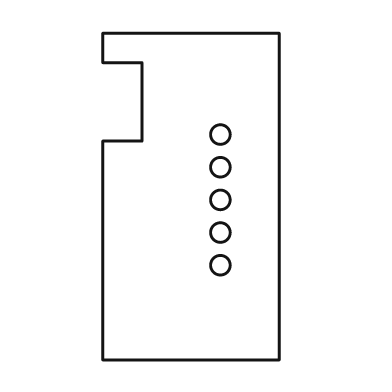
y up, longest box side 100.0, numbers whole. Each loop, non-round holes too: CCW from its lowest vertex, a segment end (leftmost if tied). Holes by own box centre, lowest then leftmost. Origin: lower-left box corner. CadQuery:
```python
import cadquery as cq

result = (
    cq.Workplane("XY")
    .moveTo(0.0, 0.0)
    .lineTo(54.0, 0.0)
    .lineTo(54.0, 100.0)
    .lineTo(0.0, 100.0)
    .lineTo(0.0, 91.0)
    .lineTo(12.0, 91.0)
    .lineTo(12.0, 67.0)
    .lineTo(0.0, 67.0)
    .close()
    .moveTo(36.0, 29.0)
    .circle(3.0)
    .moveTo(36.0, 39.0)
    .circle(3.0)
    .moveTo(36.0, 49.0)
    .circle(3.0)
    .moveTo(36.0, 59.0)
    .circle(3.0)
    .moveTo(36.0, 69.0)
    .circle(3.0)
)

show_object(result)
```